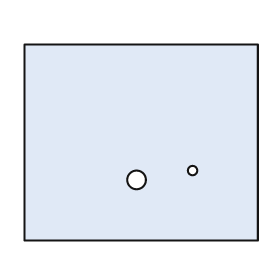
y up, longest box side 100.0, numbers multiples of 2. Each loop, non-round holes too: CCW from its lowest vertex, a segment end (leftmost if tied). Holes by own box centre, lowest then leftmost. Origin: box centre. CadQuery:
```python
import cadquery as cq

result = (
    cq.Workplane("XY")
    .moveTo(-50.0, -42.0)
    .lineTo(50.0, -42.0)
    .lineTo(50.0, 42.0)
    .lineTo(-50.0, 42.0)
    .close()
    .moveTo(-2.0, -16.0)
    .circle(4.0)
    .moveTo(22.0, -12.0)
    .circle(2.0)
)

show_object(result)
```